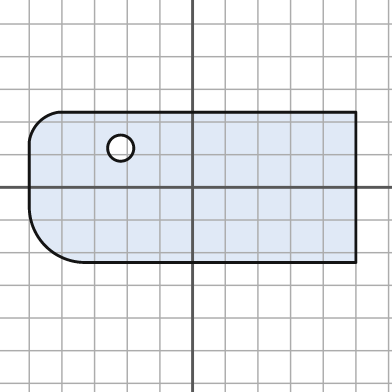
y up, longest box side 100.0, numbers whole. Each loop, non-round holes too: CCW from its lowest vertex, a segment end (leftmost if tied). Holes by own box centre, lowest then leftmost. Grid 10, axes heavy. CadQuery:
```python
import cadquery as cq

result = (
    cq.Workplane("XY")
    .moveTo(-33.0, -23.0)
    .lineTo(50.0, -23.0)
    .lineTo(50.0, 23.0)
    .lineTo(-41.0, 23.0)
    .threePointArc((-47.0, 20.0), (-50.0, 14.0))
    .lineTo(-50.0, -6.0)
    .threePointArc((-45.0, -18.0), (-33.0, -23.0))
    .close()
    .moveTo(-22.0, 12.0)
    .circle(4.0)
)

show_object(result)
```